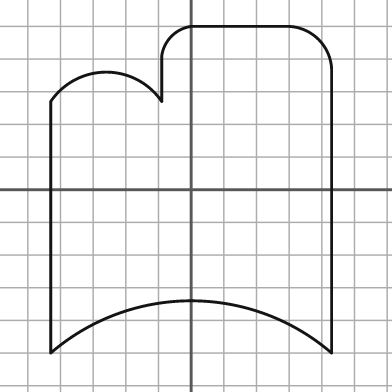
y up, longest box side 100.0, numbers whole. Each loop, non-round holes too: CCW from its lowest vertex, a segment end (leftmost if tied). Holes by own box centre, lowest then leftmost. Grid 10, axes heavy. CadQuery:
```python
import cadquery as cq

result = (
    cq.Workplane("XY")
    .moveTo(-43.0, -50.0)
    .threePointArc((0.0, -34.0), (43.0, -50.0))
    .lineTo(43.0, 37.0)
    .threePointArc((39.0, 46.0), (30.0, 50.0))
    .lineTo(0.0, 50.0)
    .threePointArc((-6.0, 47.0), (-9.0, 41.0))
    .lineTo(-9.0, 27.0)
    .threePointArc((-26.0, 36.0), (-43.0, 27.0))
    .close()
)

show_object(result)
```